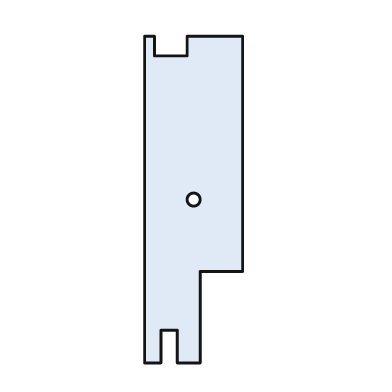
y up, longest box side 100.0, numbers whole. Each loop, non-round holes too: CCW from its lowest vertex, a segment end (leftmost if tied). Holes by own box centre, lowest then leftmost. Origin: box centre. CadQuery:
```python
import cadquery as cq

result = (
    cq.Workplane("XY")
    .moveTo(-15.0, -50.0)
    .lineTo(-10.0, -50.0)
    .lineTo(-10.0, -40.0)
    .lineTo(-5.0, -40.0)
    .lineTo(-5.0, -50.0)
    .lineTo(2.0, -50.0)
    .lineTo(2.0, -22.0)
    .lineTo(15.0, -22.0)
    .lineTo(15.0, 50.0)
    .lineTo(-2.0, 50.0)
    .lineTo(-2.0, 44.0)
    .lineTo(-12.0, 44.0)
    .lineTo(-12.0, 50.0)
    .lineTo(-15.0, 50.0)
    .close()
    .moveTo(0.0, 0.0)
    .circle(2.0)
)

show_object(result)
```